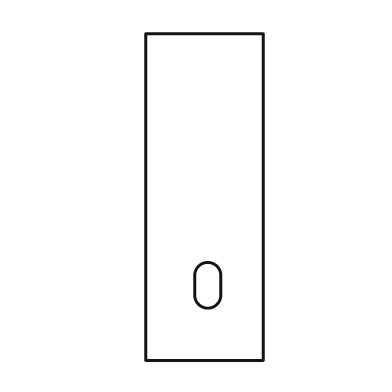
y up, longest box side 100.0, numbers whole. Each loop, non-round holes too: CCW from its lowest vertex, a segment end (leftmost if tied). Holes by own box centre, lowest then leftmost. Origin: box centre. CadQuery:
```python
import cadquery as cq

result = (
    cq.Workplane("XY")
    .moveTo(-18.0, -50.0)
    .lineTo(18.0, -50.0)
    .lineTo(18.0, 50.0)
    .lineTo(-18.0, 50.0)
    .close()
    .moveTo(-3.0, -30.0)
    .threePointArc((1.0, -34.0), (5.0, -30.0))
    .lineTo(5.0, -24.0)
    .threePointArc((1.0, -20.0), (-3.0, -24.0))
    .close()
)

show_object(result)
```